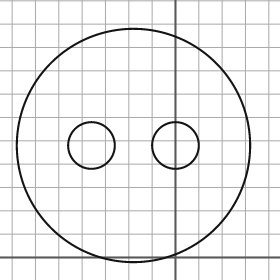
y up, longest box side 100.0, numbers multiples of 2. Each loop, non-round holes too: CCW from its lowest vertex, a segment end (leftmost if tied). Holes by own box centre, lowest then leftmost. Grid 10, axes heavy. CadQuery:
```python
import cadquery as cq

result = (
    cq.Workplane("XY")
    .moveTo(-18.0, 48.0)
    .circle(50.0)
    .moveTo(-36.0, 48.0)
    .circle(10.0)
    .moveTo(0.0, 48.0)
    .circle(10.0)
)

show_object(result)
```